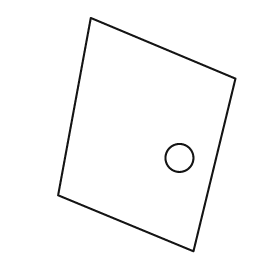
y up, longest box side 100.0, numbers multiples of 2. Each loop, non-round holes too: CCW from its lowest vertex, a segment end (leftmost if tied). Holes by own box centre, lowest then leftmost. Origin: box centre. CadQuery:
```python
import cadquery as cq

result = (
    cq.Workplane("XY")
    .moveTo(20.0, -50.0)
    .lineTo(38.0, 24.0)
    .lineTo(-24.0, 50.0)
    .lineTo(-38.0, -26.0)
    .close()
    .moveTo(14.0, -10.0)
    .circle(6.0)
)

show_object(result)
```